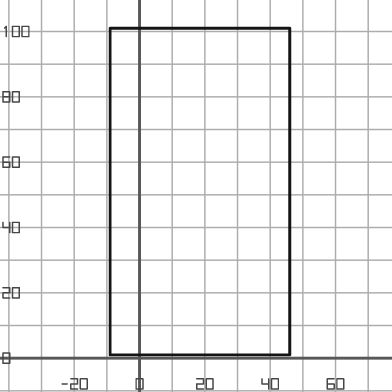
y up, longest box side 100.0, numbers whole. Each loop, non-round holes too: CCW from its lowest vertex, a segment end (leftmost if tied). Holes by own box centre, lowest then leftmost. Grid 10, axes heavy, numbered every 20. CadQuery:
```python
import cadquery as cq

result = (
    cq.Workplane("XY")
    .moveTo(-9.0, 1.0)
    .lineTo(46.0, 1.0)
    .lineTo(46.0, 101.0)
    .lineTo(-9.0, 101.0)
    .close()
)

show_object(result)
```